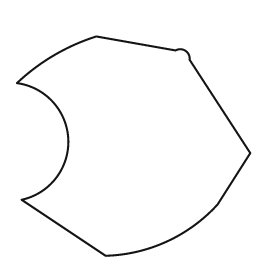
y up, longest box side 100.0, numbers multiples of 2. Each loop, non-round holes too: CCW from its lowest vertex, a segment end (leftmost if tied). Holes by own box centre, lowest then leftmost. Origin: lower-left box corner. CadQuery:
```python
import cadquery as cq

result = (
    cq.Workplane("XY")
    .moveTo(38.0, 0.0)
    .threePointArc((64.0, 6.0), (86.0, 22.0))
    .lineTo(100.0, 44.0)
    .lineTo(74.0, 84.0)
    .threePointArc((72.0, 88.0), (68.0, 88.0))
    .lineTo(34.0, 94.0)
    .threePointArc((16.0, 86.0), (0.0, 74.0))
    .threePointArc((22.0, 50.0), (2.0, 24.0))
    .close()
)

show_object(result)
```